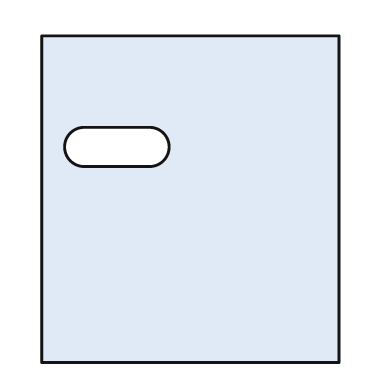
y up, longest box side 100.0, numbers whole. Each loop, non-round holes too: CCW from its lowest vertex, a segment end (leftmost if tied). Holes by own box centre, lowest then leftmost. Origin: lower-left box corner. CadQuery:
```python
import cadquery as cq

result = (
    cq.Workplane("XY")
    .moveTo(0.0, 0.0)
    .lineTo(91.0, 0.0)
    .lineTo(91.0, 100.0)
    .lineTo(0.0, 100.0)
    .close()
    .moveTo(13.0, 60.0)
    .lineTo(33.0, 60.0)
    .threePointArc((39.0, 66.0), (33.0, 72.0))
    .lineTo(13.0, 72.0)
    .threePointArc((7.0, 66.0), (13.0, 60.0))
    .close()
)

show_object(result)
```